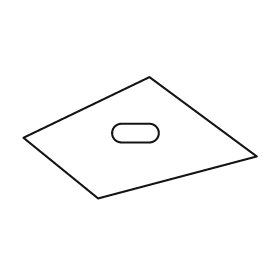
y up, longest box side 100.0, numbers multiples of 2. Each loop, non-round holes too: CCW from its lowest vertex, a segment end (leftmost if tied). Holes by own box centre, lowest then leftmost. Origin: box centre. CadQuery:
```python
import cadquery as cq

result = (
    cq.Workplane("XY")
    .moveTo(-18.0, -26.0)
    .lineTo(50.0, -8.0)
    .lineTo(4.0, 26.0)
    .lineTo(-50.0, 0.0)
    .close()
    .moveTo(-8.0, -2.0)
    .lineTo(4.0, -2.0)
    .threePointArc((8.0, 2.0), (4.0, 6.0))
    .lineTo(-8.0, 6.0)
    .threePointArc((-12.0, 2.0), (-8.0, -2.0))
    .close()
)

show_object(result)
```